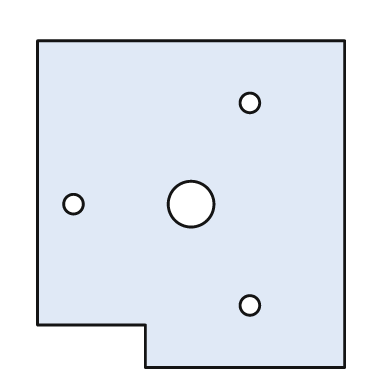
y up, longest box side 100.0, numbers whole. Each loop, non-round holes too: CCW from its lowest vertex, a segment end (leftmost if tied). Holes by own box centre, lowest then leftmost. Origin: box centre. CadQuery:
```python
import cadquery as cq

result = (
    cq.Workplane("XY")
    .moveTo(-14.0, -50.0)
    .lineTo(47.0, -50.0)
    .lineTo(47.0, 50.0)
    .lineTo(-47.0, 50.0)
    .lineTo(-47.0, -37.0)
    .lineTo(-14.0, -37.0)
    .close()
    .moveTo(18.0, -31.0)
    .circle(3.0)
    .moveTo(-36.0, 0.0)
    .circle(3.0)
    .moveTo(0.0, 0.0)
    .circle(7.0)
    .moveTo(18.0, 31.0)
    .circle(3.0)
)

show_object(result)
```